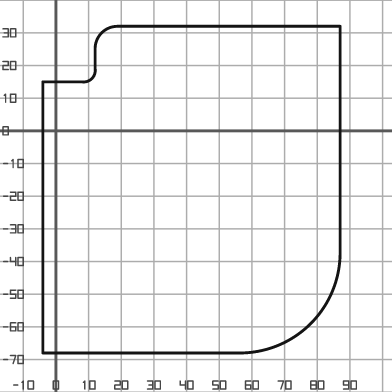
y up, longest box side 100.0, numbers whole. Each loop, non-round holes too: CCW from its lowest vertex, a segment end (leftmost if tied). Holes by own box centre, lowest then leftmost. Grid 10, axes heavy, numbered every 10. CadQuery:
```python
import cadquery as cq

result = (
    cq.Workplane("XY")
    .moveTo(-4.0, -68.0)
    .lineTo(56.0, -68.0)
    .threePointArc((78.0, -59.0), (87.0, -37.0))
    .lineTo(87.0, 32.0)
    .lineTo(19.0, 32.0)
    .threePointArc((14.0, 30.0), (12.0, 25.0))
    .lineTo(12.0, 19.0)
    .threePointArc((11.0, 16.0), (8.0, 15.0))
    .lineTo(-4.0, 15.0)
    .close()
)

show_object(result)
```